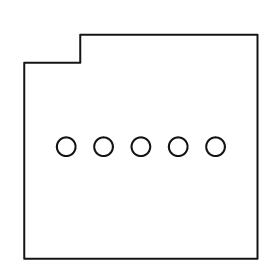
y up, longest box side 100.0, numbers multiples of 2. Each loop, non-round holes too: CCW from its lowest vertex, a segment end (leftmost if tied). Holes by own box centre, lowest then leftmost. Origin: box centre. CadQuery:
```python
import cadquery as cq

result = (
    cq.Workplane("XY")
    .moveTo(-50.0, -48.0)
    .lineTo(50.0, -48.0)
    .lineTo(50.0, 48.0)
    .lineTo(-26.0, 48.0)
    .lineTo(-26.0, 36.0)
    .lineTo(-50.0, 36.0)
    .close()
    .moveTo(-32.0, 0.0)
    .circle(4.0)
    .moveTo(-16.0, 0.0)
    .circle(4.0)
    .moveTo(0.0, 0.0)
    .circle(4.0)
    .moveTo(16.0, 0.0)
    .circle(4.0)
    .moveTo(32.0, 0.0)
    .circle(4.0)
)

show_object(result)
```